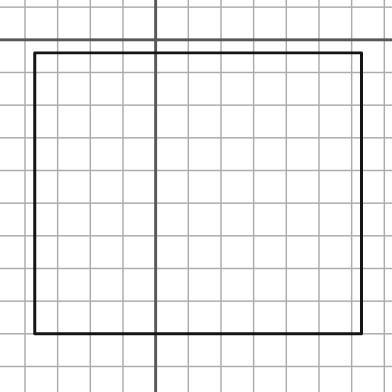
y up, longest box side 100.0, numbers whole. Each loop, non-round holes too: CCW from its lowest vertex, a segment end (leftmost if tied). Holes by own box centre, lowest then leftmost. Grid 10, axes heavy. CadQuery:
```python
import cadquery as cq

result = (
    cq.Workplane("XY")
    .moveTo(-37.0, -90.0)
    .lineTo(63.0, -90.0)
    .lineTo(63.0, -4.0)
    .lineTo(-37.0, -4.0)
    .close()
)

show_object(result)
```